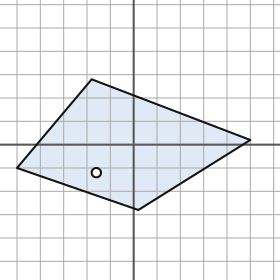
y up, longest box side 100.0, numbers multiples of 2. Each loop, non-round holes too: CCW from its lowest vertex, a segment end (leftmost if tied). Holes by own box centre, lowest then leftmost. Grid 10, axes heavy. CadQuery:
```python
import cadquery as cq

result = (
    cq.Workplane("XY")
    .moveTo(2.0, -28.0)
    .lineTo(50.0, 2.0)
    .lineTo(-18.0, 28.0)
    .lineTo(-50.0, -10.0)
    .close()
    .moveTo(-16.0, -12.0)
    .circle(2.0)
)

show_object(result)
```